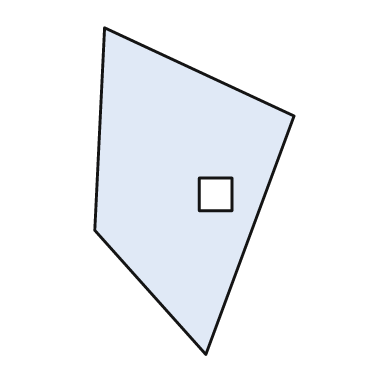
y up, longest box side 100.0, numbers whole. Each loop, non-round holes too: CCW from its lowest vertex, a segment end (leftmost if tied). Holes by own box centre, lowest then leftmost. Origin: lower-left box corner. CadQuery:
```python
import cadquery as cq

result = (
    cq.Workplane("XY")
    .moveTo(34.0, 0.0)
    .lineTo(61.0, 73.0)
    .lineTo(3.0, 100.0)
    .lineTo(0.0, 38.0)
    .close()
    .moveTo(32.0, 44.0)
    .lineTo(42.0, 44.0)
    .lineTo(42.0, 54.0)
    .lineTo(32.0, 54.0)
    .close()
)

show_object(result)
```